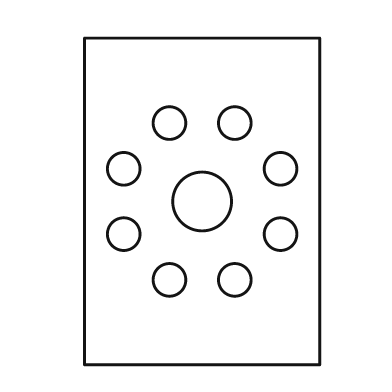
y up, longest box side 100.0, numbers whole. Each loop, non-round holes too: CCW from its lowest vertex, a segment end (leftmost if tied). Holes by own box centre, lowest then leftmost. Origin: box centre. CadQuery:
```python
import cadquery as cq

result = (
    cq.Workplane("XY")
    .moveTo(-36.0, -50.0)
    .lineTo(36.0, -50.0)
    .lineTo(36.0, 50.0)
    .lineTo(-36.0, 50.0)
    .close()
    .moveTo(-10.0, -24.0)
    .circle(5.0)
    .moveTo(10.0, -24.0)
    .circle(5.0)
    .moveTo(-24.0, -10.0)
    .circle(5.0)
    .moveTo(24.0, -10.0)
    .circle(5.0)
    .moveTo(0.0, 0.0)
    .circle(9.0)
    .moveTo(-24.0, 10.0)
    .circle(5.0)
    .moveTo(24.0, 10.0)
    .circle(5.0)
    .moveTo(-10.0, 24.0)
    .circle(5.0)
    .moveTo(10.0, 24.0)
    .circle(5.0)
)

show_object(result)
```